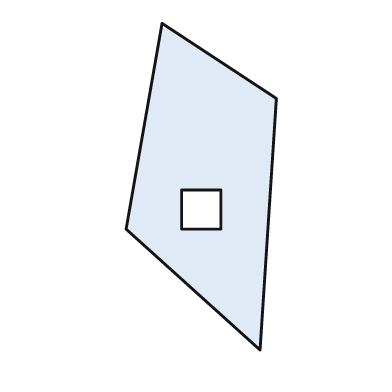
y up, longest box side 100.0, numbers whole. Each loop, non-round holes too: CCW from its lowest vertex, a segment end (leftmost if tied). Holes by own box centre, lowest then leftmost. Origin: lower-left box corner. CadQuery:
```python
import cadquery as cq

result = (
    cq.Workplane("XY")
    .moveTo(41.0, 0.0)
    .lineTo(46.0, 77.0)
    .lineTo(11.0, 100.0)
    .lineTo(0.0, 37.0)
    .close()
    .moveTo(17.0, 37.0)
    .lineTo(29.0, 37.0)
    .lineTo(29.0, 49.0)
    .lineTo(17.0, 49.0)
    .close()
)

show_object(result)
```